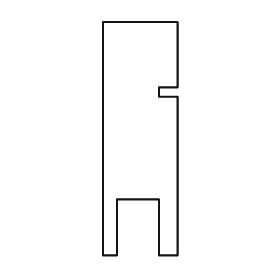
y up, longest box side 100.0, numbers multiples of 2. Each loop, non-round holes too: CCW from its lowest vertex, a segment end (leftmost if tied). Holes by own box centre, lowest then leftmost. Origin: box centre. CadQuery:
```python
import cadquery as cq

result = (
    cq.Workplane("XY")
    .moveTo(-16.0, -50.0)
    .lineTo(-10.0, -50.0)
    .lineTo(-10.0, -26.0)
    .lineTo(8.0, -26.0)
    .lineTo(8.0, -50.0)
    .lineTo(16.0, -50.0)
    .lineTo(16.0, 18.0)
    .lineTo(8.0, 18.0)
    .lineTo(8.0, 22.0)
    .lineTo(16.0, 22.0)
    .lineTo(16.0, 50.0)
    .lineTo(-16.0, 50.0)
    .close()
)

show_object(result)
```